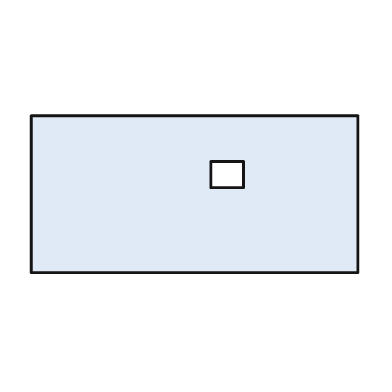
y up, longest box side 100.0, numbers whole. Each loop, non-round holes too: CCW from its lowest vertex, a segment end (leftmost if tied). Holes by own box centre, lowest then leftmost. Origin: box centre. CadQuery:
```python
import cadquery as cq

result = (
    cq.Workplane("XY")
    .moveTo(-50.0, -24.0)
    .lineTo(50.0, -24.0)
    .lineTo(50.0, 24.0)
    .lineTo(-50.0, 24.0)
    .close()
    .moveTo(5.0, 2.0)
    .lineTo(15.0, 2.0)
    .lineTo(15.0, 10.0)
    .lineTo(5.0, 10.0)
    .close()
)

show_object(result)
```